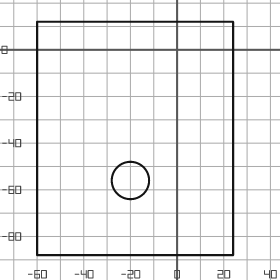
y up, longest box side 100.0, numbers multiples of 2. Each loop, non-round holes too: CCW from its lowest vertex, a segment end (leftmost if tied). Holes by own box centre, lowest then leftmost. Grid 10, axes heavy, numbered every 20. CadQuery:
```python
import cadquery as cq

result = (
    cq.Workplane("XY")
    .moveTo(-60.0, -88.0)
    .lineTo(24.0, -88.0)
    .lineTo(24.0, 12.0)
    .lineTo(-60.0, 12.0)
    .close()
    .moveTo(-20.0, -56.0)
    .circle(8.0)
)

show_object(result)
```